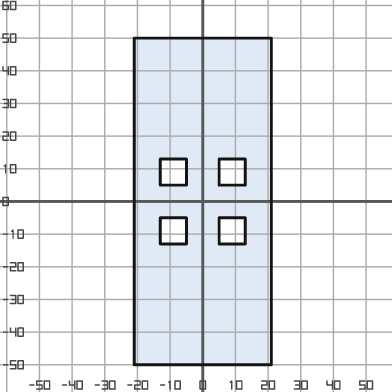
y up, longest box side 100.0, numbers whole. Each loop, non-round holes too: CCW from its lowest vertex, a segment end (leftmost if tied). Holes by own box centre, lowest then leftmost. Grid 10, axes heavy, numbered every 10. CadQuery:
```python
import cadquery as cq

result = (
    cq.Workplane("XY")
    .moveTo(-21.0, -50.0)
    .lineTo(21.0, -50.0)
    .lineTo(21.0, 50.0)
    .lineTo(-21.0, 50.0)
    .close()
    .moveTo(-13.0, -13.0)
    .lineTo(-5.0, -13.0)
    .lineTo(-5.0, -5.0)
    .lineTo(-13.0, -5.0)
    .close()
    .moveTo(5.0, -13.0)
    .lineTo(13.0, -13.0)
    .lineTo(13.0, -5.0)
    .lineTo(5.0, -5.0)
    .close()
    .moveTo(-13.0, 5.0)
    .lineTo(-5.0, 5.0)
    .lineTo(-5.0, 13.0)
    .lineTo(-13.0, 13.0)
    .close()
    .moveTo(5.0, 5.0)
    .lineTo(13.0, 5.0)
    .lineTo(13.0, 13.0)
    .lineTo(5.0, 13.0)
    .close()
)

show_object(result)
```